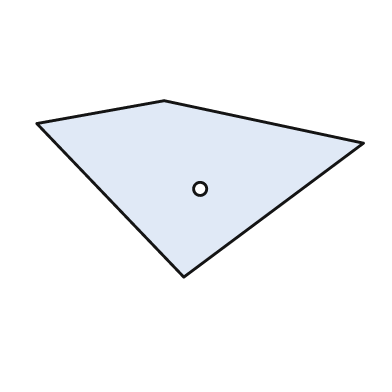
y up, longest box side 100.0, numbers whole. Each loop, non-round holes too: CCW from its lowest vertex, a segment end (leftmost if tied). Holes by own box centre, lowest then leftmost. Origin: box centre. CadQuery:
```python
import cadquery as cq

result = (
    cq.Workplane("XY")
    .moveTo(-5.0, -27.0)
    .lineTo(50.0, 14.0)
    .lineTo(-11.0, 27.0)
    .lineTo(-50.0, 20.0)
    .close()
    .moveTo(0.0, 0.0)
    .circle(2.0)
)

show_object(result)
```